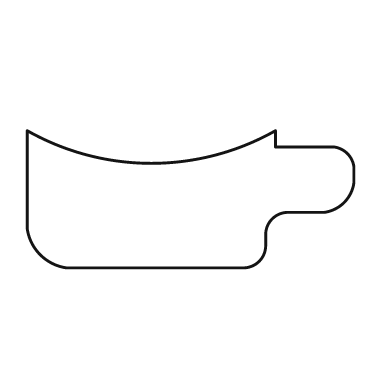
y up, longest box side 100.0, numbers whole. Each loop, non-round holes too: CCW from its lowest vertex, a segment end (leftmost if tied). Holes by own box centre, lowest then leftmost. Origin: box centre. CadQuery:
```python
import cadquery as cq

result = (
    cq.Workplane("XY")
    .moveTo(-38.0, -21.0)
    .lineTo(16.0, -21.0)
    .threePointArc((21.0, -19.0), (23.0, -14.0))
    .lineTo(23.0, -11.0)
    .threePointArc((25.0, -6.0), (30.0, -4.0))
    .lineTo(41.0, -4.0)
    .threePointArc((47.0, -1.0), (50.0, 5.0))
    .lineTo(50.0, 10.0)
    .threePointArc((48.0, 14.0), (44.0, 16.0))
    .lineTo(26.0, 16.0)
    .lineTo(26.0, 21.0)
    .threePointArc((-12.0, 11.0), (-50.0, 21.0))
    .lineTo(-50.0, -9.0)
    .threePointArc((-46.0, -17.0), (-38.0, -21.0))
    .close()
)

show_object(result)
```